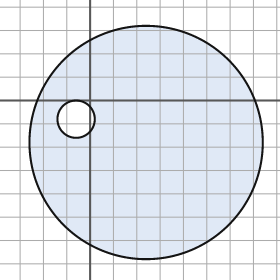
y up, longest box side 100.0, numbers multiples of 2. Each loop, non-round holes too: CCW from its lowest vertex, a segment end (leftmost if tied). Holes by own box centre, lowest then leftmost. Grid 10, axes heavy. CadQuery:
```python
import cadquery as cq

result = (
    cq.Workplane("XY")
    .moveTo(24.0, -18.0)
    .circle(50.0)
    .moveTo(-6.0, -8.0)
    .circle(8.0)
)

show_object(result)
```